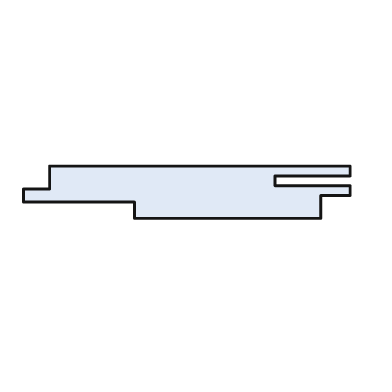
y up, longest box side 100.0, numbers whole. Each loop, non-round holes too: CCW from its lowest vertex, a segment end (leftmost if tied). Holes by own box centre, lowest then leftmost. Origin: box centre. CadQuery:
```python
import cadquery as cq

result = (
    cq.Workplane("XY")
    .moveTo(-16.0, -8.0)
    .lineTo(41.0, -8.0)
    .lineTo(41.0, -1.0)
    .lineTo(50.0, -1.0)
    .lineTo(50.0, 2.0)
    .lineTo(27.0, 2.0)
    .lineTo(27.0, 5.0)
    .lineTo(50.0, 5.0)
    .lineTo(50.0, 8.0)
    .lineTo(-42.0, 8.0)
    .lineTo(-42.0, 1.0)
    .lineTo(-50.0, 1.0)
    .lineTo(-50.0, -3.0)
    .lineTo(-16.0, -3.0)
    .close()
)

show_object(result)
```